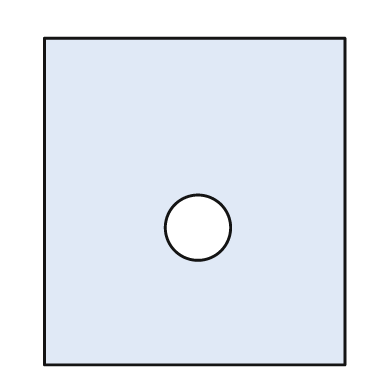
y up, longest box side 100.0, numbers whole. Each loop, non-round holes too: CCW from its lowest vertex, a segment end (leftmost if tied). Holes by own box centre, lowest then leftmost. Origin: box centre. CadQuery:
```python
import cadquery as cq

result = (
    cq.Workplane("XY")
    .moveTo(-46.0, -50.0)
    .lineTo(46.0, -50.0)
    .lineTo(46.0, 50.0)
    .lineTo(-46.0, 50.0)
    .close()
    .moveTo(1.0, -8.0)
    .circle(10.0)
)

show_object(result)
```